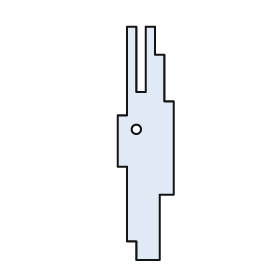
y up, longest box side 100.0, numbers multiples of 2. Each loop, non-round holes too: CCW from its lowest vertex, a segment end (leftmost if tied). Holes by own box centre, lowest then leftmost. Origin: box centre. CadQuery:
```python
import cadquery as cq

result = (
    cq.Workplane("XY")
    .moveTo(-4.0, -50.0)
    .lineTo(6.0, -50.0)
    .lineTo(6.0, -22.0)
    .lineTo(12.0, -22.0)
    .lineTo(12.0, 18.0)
    .lineTo(8.0, 18.0)
    .lineTo(8.0, 38.0)
    .lineTo(4.0, 38.0)
    .lineTo(4.0, 50.0)
    .lineTo(0.0, 50.0)
    .lineTo(0.0, 22.0)
    .lineTo(-4.0, 22.0)
    .lineTo(-4.0, 50.0)
    .lineTo(-8.0, 50.0)
    .lineTo(-8.0, 12.0)
    .lineTo(-12.0, 12.0)
    .lineTo(-12.0, -10.0)
    .lineTo(-8.0, -10.0)
    .lineTo(-8.0, -42.0)
    .lineTo(-4.0, -42.0)
    .close()
    .moveTo(-4.0, 6.0)
    .circle(2.0)
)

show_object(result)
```